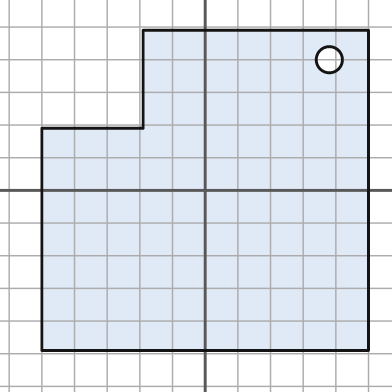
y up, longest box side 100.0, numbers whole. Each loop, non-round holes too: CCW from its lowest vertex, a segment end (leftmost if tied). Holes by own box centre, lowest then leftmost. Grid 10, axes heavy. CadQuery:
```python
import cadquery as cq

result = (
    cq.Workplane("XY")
    .moveTo(-50.0, -49.0)
    .lineTo(50.0, -49.0)
    .lineTo(50.0, 49.0)
    .lineTo(-19.0, 49.0)
    .lineTo(-19.0, 19.0)
    .lineTo(-50.0, 19.0)
    .close()
    .moveTo(38.0, 40.0)
    .circle(4.0)
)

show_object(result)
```